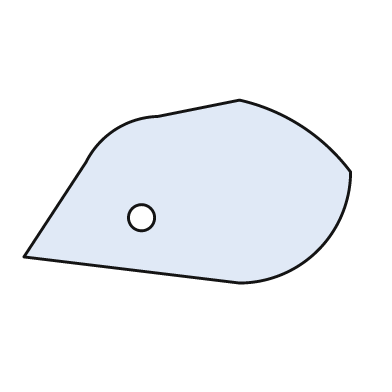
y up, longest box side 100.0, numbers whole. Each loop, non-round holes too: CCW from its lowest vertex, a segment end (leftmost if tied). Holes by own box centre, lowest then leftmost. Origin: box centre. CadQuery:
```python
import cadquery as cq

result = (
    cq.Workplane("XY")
    .moveTo(16.0, -28.0)
    .threePointArc((40.0, -18.0), (50.0, 6.0))
    .threePointArc((35.0, 20.0), (16.0, 28.0))
    .lineTo(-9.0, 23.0)
    .threePointArc((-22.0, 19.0), (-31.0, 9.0))
    .lineTo(-50.0, -20.0)
    .close()
    .moveTo(-14.0, -8.0)
    .circle(4.0)
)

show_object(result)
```